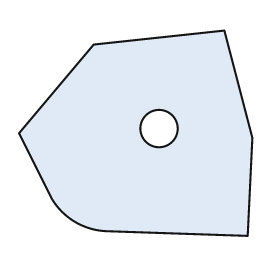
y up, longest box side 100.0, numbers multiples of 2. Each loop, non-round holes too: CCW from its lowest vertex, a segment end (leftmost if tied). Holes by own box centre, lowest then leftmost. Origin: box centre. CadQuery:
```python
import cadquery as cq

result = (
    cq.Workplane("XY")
    .moveTo(48.0, -44.0)
    .lineTo(50.0, -2.0)
    .lineTo(38.0, 44.0)
    .lineTo(-18.0, 38.0)
    .lineTo(-50.0, 0.0)
    .lineTo(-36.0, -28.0)
    .threePointArc((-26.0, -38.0), (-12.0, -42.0))
    .close()
    .moveTo(10.0, 2.0)
    .circle(8.0)
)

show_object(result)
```